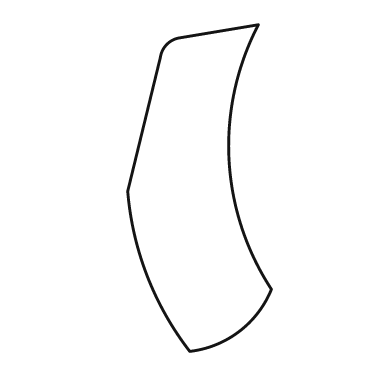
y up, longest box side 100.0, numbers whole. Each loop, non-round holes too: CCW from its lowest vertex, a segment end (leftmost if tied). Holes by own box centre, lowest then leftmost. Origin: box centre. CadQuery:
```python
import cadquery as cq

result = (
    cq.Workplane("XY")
    .moveTo(-3.0, -50.0)
    .threePointArc((12.0, -44.0), (22.0, -31.0))
    .threePointArc((9.0, 9.0), (18.0, 50.0))
    .lineTo(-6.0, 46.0)
    .threePointArc((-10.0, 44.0), (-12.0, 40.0))
    .lineTo(-22.0, -1.0)
    .threePointArc((-16.0, -27.0), (-3.0, -50.0))
    .close()
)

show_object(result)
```